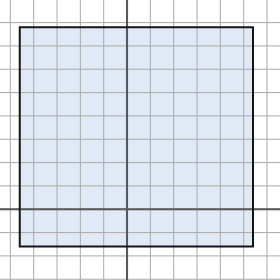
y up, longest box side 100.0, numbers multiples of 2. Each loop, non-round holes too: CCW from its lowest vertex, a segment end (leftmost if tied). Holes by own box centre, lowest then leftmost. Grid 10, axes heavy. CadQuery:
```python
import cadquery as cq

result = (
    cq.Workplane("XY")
    .moveTo(-46.0, -16.0)
    .lineTo(54.0, -16.0)
    .lineTo(54.0, 78.0)
    .lineTo(-46.0, 78.0)
    .close()
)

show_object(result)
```